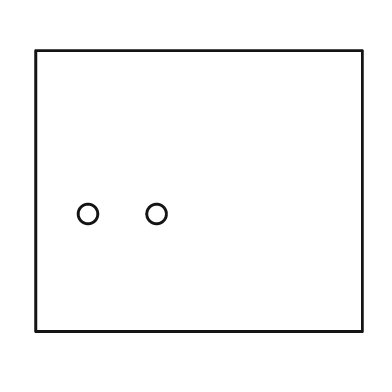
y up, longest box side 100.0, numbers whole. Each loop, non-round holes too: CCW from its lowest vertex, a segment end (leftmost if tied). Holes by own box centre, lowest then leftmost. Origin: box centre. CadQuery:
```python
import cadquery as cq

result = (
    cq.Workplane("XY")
    .moveTo(-50.0, -43.0)
    .lineTo(50.0, -43.0)
    .lineTo(50.0, 43.0)
    .lineTo(-50.0, 43.0)
    .close()
    .moveTo(-34.0, -7.0)
    .circle(3.0)
    .moveTo(-13.0, -7.0)
    .circle(3.0)
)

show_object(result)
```